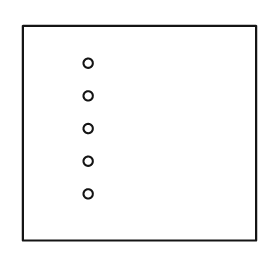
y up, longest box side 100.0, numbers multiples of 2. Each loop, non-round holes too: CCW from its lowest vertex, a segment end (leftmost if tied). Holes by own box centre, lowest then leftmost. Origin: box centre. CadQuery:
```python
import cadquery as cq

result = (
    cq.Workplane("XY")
    .moveTo(-50.0, -46.0)
    .lineTo(50.0, -46.0)
    .lineTo(50.0, 46.0)
    .lineTo(-50.0, 46.0)
    .close()
    .moveTo(-22.0, -26.0)
    .circle(2.0)
    .moveTo(-22.0, -12.0)
    .circle(2.0)
    .moveTo(-22.0, 2.0)
    .circle(2.0)
    .moveTo(-22.0, 16.0)
    .circle(2.0)
    .moveTo(-22.0, 30.0)
    .circle(2.0)
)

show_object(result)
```